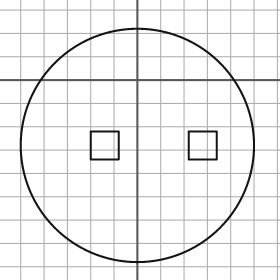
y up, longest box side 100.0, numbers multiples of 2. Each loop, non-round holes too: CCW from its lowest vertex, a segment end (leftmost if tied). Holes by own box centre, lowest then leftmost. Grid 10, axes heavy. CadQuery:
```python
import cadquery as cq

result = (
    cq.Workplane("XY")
    .moveTo(0.0, -28.0)
    .circle(50.0)
    .moveTo(-20.0, -34.0)
    .lineTo(-8.0, -34.0)
    .lineTo(-8.0, -22.0)
    .lineTo(-20.0, -22.0)
    .close()
    .moveTo(22.0, -34.0)
    .lineTo(34.0, -34.0)
    .lineTo(34.0, -22.0)
    .lineTo(22.0, -22.0)
    .close()
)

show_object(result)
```